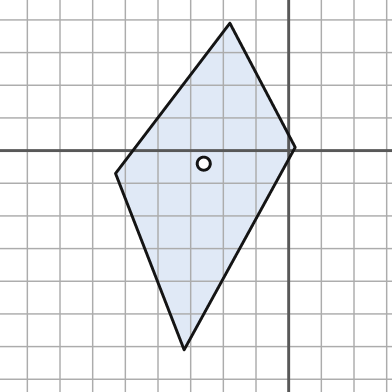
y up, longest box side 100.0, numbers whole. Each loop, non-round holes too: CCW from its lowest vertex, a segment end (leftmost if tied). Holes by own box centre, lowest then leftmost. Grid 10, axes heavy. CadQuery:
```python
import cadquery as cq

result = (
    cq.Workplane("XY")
    .moveTo(-32.0, -61.0)
    .lineTo(2.0, 1.0)
    .lineTo(-18.0, 39.0)
    .lineTo(-53.0, -7.0)
    .close()
    .moveTo(-26.0, -4.0)
    .circle(2.0)
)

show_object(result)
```